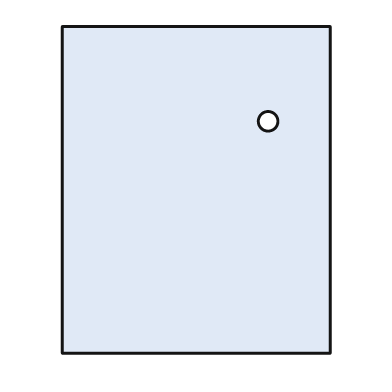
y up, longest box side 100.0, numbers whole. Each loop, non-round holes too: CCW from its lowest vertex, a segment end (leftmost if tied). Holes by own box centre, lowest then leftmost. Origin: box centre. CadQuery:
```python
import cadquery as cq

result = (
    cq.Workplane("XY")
    .moveTo(-41.0, -50.0)
    .lineTo(41.0, -50.0)
    .lineTo(41.0, 50.0)
    .lineTo(-41.0, 50.0)
    .close()
    .moveTo(22.0, 21.0)
    .circle(3.0)
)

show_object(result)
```